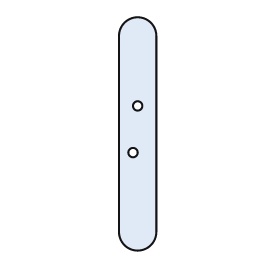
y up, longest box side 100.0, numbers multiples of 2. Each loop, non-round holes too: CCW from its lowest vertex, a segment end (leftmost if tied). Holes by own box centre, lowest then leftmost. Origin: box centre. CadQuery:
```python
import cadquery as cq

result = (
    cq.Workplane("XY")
    .moveTo(-8.0, -42.0)
    .threePointArc((0.0, -50.0), (8.0, -42.0))
    .lineTo(8.0, 42.0)
    .threePointArc((0.0, 50.0), (-8.0, 42.0))
    .close()
    .moveTo(-2.0, -8.0)
    .circle(2.0)
    .moveTo(0.0, 12.0)
    .circle(2.0)
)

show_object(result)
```